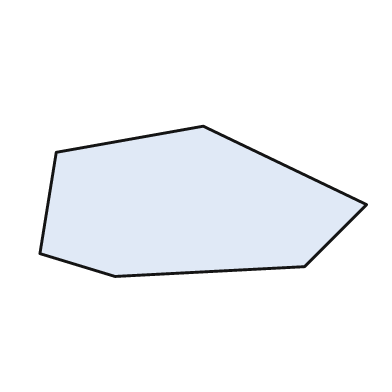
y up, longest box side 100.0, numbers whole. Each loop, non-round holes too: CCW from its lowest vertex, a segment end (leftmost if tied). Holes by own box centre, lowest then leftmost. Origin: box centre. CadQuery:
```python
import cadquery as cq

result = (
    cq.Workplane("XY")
    .moveTo(-27.0, -23.0)
    .lineTo(31.0, -20.0)
    .lineTo(50.0, -1.0)
    .lineTo(0.0, 23.0)
    .lineTo(-45.0, 15.0)
    .lineTo(-50.0, -16.0)
    .close()
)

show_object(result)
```